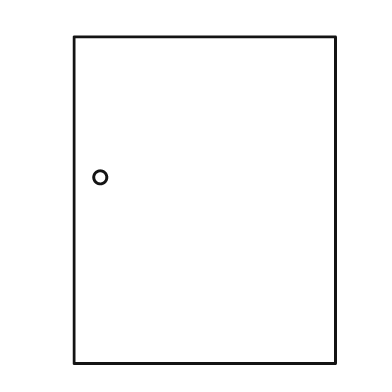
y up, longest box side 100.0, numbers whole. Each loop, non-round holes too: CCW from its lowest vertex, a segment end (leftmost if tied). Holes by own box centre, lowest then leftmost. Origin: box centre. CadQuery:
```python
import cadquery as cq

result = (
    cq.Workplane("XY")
    .moveTo(-40.0, -50.0)
    .lineTo(40.0, -50.0)
    .lineTo(40.0, 50.0)
    .lineTo(-40.0, 50.0)
    .close()
    .moveTo(-32.0, 7.0)
    .circle(2.0)
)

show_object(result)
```